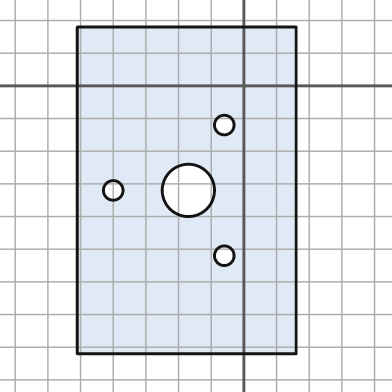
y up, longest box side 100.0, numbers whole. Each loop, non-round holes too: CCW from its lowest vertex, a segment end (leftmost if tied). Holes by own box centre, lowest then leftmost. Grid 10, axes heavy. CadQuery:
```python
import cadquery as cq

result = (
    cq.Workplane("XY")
    .moveTo(-51.0, -82.0)
    .lineTo(16.0, -82.0)
    .lineTo(16.0, 18.0)
    .lineTo(-51.0, 18.0)
    .close()
    .moveTo(-6.0, -52.0)
    .circle(3.0)
    .moveTo(-40.0, -32.0)
    .circle(3.0)
    .moveTo(-17.0, -32.0)
    .circle(8.0)
    .moveTo(-6.0, -12.0)
    .circle(3.0)
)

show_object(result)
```